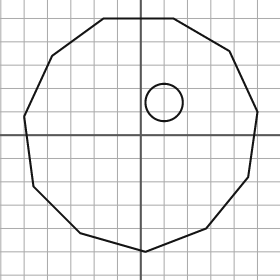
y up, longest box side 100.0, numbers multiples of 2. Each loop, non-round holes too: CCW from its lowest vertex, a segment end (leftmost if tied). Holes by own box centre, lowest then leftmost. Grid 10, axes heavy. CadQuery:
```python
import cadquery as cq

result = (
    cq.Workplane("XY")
    .moveTo(2.0, -50.0)
    .lineTo(28.0, -40.0)
    .lineTo(46.0, -18.0)
    .lineTo(50.0, 10.0)
    .lineTo(38.0, 36.0)
    .lineTo(14.0, 50.0)
    .lineTo(-16.0, 50.0)
    .lineTo(-38.0, 34.0)
    .lineTo(-50.0, 8.0)
    .lineTo(-46.0, -22.0)
    .lineTo(-26.0, -42.0)
    .close()
    .moveTo(10.0, 14.0)
    .circle(8.0)
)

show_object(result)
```